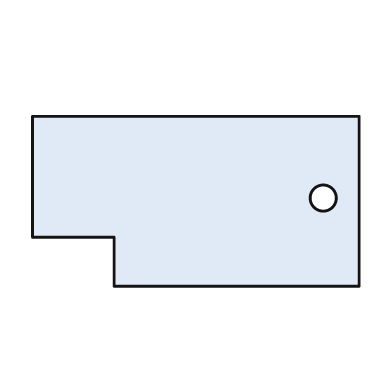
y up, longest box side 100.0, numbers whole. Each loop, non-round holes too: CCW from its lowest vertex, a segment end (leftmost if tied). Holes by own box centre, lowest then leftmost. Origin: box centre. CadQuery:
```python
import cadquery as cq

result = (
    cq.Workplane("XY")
    .moveTo(-25.0, -26.0)
    .lineTo(50.0, -26.0)
    .lineTo(50.0, 26.0)
    .lineTo(-50.0, 26.0)
    .lineTo(-50.0, -11.0)
    .lineTo(-25.0, -11.0)
    .close()
    .moveTo(39.0, 1.0)
    .circle(4.0)
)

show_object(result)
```